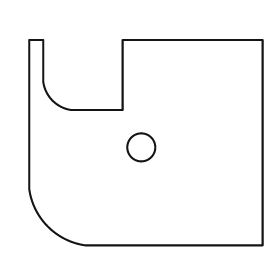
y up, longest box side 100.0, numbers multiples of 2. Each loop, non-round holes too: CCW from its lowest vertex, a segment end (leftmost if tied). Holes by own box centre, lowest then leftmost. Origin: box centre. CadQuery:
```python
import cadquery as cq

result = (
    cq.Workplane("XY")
    .moveTo(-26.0, -44.0)
    .lineTo(50.0, -44.0)
    .lineTo(50.0, 44.0)
    .lineTo(-10.0, 44.0)
    .lineTo(-10.0, 14.0)
    .lineTo(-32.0, 14.0)
    .threePointArc((-40.0, 18.0), (-44.0, 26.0))
    .lineTo(-44.0, 44.0)
    .lineTo(-50.0, 44.0)
    .lineTo(-50.0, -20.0)
    .threePointArc((-42.0, -36.0), (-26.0, -44.0))
    .close()
    .moveTo(-2.0, -2.0)
    .circle(6.0)
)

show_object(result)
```